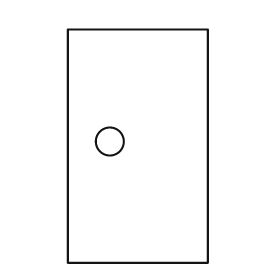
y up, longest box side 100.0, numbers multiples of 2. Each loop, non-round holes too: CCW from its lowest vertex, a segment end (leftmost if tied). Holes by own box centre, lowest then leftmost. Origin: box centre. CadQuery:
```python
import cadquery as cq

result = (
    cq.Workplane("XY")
    .moveTo(-30.0, -50.0)
    .lineTo(30.0, -50.0)
    .lineTo(30.0, 50.0)
    .lineTo(-30.0, 50.0)
    .close()
    .moveTo(-12.0, 2.0)
    .circle(6.0)
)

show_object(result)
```